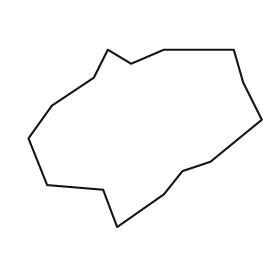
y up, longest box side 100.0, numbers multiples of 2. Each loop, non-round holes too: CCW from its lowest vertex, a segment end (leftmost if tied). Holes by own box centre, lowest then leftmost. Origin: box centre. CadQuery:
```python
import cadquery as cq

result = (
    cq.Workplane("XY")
    .moveTo(-12.0, -38.0)
    .lineTo(8.0, -24.0)
    .lineTo(16.0, -14.0)
    .lineTo(28.0, -10.0)
    .lineTo(50.0, 8.0)
    .lineTo(42.0, 24.0)
    .lineTo(38.0, 38.0)
    .lineTo(8.0, 38.0)
    .lineTo(-6.0, 32.0)
    .lineTo(-16.0, 38.0)
    .lineTo(-22.0, 26.0)
    .lineTo(-40.0, 14.0)
    .lineTo(-50.0, 0.0)
    .lineTo(-42.0, -20.0)
    .lineTo(-18.0, -22.0)
    .close()
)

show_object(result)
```